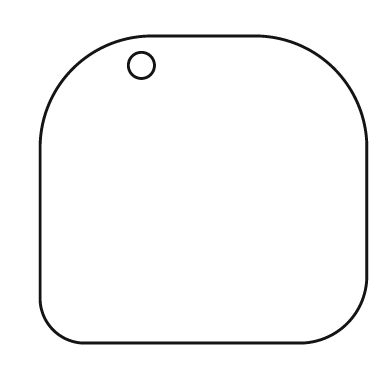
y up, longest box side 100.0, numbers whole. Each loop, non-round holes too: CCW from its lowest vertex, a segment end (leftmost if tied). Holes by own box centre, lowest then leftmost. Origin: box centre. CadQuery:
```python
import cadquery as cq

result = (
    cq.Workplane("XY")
    .moveTo(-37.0, -47.0)
    .lineTo(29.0, -47.0)
    .threePointArc((44.0, -41.0), (50.0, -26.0))
    .lineTo(50.0, 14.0)
    .threePointArc((40.0, 37.0), (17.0, 47.0))
    .lineTo(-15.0, 47.0)
    .threePointArc((-40.0, 37.0), (-50.0, 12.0))
    .lineTo(-50.0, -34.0)
    .threePointArc((-46.0, -43.0), (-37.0, -47.0))
    .close()
    .moveTo(-19.0, 38.0)
    .circle(4.0)
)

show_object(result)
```